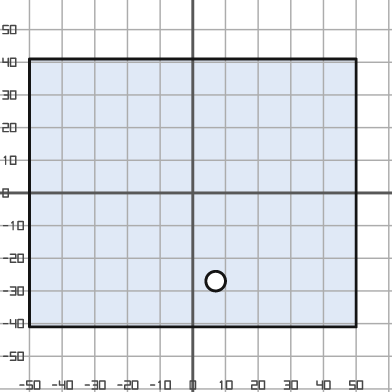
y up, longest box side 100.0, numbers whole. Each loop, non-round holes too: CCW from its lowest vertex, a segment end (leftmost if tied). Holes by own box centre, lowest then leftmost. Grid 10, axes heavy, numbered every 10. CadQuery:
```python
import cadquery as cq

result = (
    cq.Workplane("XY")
    .moveTo(-50.0, -41.0)
    .lineTo(50.0, -41.0)
    .lineTo(50.0, 41.0)
    .lineTo(-50.0, 41.0)
    .close()
    .moveTo(7.0, -27.0)
    .circle(3.0)
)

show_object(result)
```